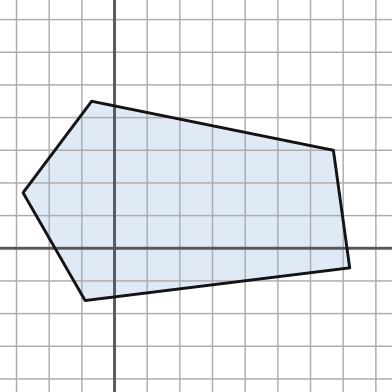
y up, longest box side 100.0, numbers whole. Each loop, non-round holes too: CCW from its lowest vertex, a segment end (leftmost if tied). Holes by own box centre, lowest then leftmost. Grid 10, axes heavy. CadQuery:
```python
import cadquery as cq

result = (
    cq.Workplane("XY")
    .moveTo(-9.0, -16.0)
    .lineTo(72.0, -6.0)
    .lineTo(67.0, 30.0)
    .lineTo(-7.0, 45.0)
    .lineTo(-28.0, 17.0)
    .close()
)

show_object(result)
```